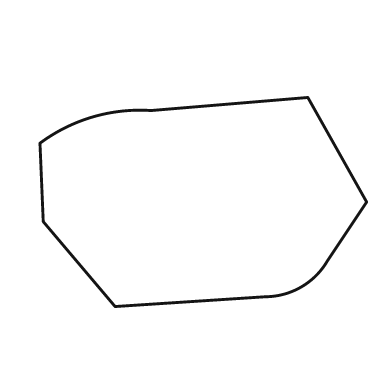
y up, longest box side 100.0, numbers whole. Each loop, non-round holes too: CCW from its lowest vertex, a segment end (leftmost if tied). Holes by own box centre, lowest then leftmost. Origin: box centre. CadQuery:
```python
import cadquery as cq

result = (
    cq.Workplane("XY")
    .moveTo(-27.0, -32.0)
    .lineTo(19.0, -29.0)
    .threePointArc((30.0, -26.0), (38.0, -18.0))
    .lineTo(50.0, 0.0)
    .lineTo(32.0, 32.0)
    .lineTo(-16.0, 28.0)
    .threePointArc((-34.0, 26.0), (-50.0, 18.0))
    .lineTo(-49.0, -6.0)
    .close()
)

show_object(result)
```